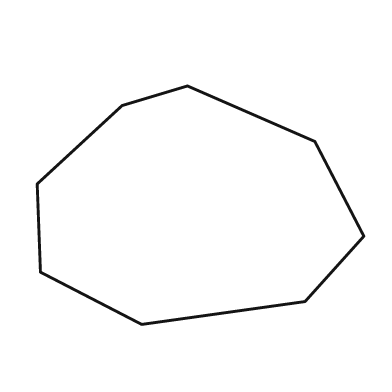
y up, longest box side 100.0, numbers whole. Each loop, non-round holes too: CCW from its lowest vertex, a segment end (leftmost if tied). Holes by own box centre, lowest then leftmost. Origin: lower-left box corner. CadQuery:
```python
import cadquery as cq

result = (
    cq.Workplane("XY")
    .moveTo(32.0, 0.0)
    .lineTo(82.0, 7.0)
    .lineTo(100.0, 27.0)
    .lineTo(85.0, 56.0)
    .lineTo(46.0, 73.0)
    .lineTo(26.0, 67.0)
    .lineTo(0.0, 43.0)
    .lineTo(1.0, 16.0)
    .close()
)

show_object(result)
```